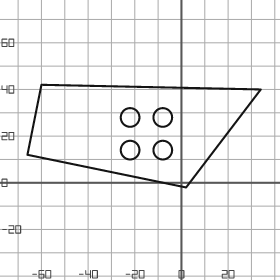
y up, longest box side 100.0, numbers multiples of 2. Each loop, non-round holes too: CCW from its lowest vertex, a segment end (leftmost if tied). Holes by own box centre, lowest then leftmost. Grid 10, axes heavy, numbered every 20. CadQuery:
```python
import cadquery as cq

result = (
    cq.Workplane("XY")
    .moveTo(2.0, -2.0)
    .lineTo(34.0, 40.0)
    .lineTo(-60.0, 42.0)
    .lineTo(-66.0, 12.0)
    .close()
    .moveTo(-22.0, 14.0)
    .circle(4.0)
    .moveTo(-8.0, 14.0)
    .circle(4.0)
    .moveTo(-22.0, 28.0)
    .circle(4.0)
    .moveTo(-8.0, 28.0)
    .circle(4.0)
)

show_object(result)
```